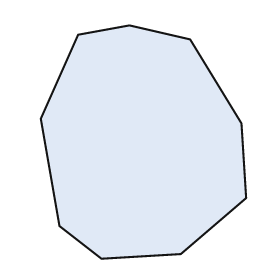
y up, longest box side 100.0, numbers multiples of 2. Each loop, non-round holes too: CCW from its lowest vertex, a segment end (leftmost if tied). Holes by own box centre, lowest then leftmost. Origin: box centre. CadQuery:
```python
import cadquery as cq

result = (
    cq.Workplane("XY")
    .moveTo(-18.0, -50.0)
    .lineTo(16.0, -48.0)
    .lineTo(44.0, -24.0)
    .lineTo(42.0, 8.0)
    .lineTo(20.0, 44.0)
    .lineTo(-6.0, 50.0)
    .lineTo(-28.0, 46.0)
    .lineTo(-44.0, 10.0)
    .lineTo(-36.0, -36.0)
    .close()
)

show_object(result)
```